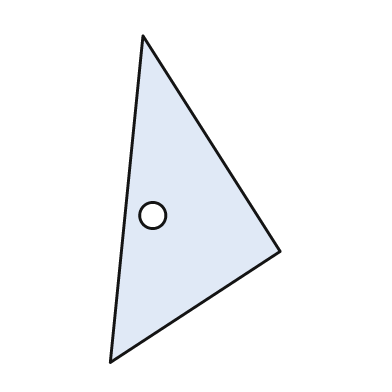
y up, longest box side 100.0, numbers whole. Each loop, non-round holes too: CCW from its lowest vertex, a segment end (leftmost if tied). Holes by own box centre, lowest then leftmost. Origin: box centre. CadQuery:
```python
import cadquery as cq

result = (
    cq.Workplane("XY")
    .moveTo(-26.0, -50.0)
    .lineTo(26.0, -16.0)
    .lineTo(-16.0, 50.0)
    .close()
    .moveTo(-13.0, -5.0)
    .circle(4.0)
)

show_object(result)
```